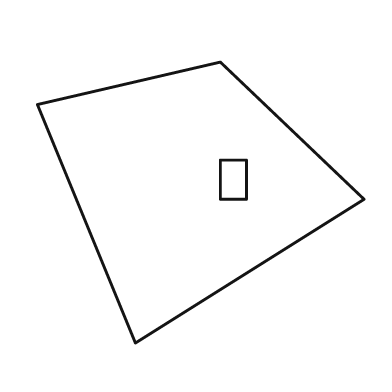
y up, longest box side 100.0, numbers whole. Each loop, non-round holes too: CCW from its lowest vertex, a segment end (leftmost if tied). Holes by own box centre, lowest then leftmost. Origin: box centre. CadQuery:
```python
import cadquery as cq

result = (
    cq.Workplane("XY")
    .moveTo(-20.0, -43.0)
    .lineTo(50.0, 1.0)
    .lineTo(6.0, 43.0)
    .lineTo(-50.0, 30.0)
    .close()
    .moveTo(6.0, 1.0)
    .lineTo(14.0, 1.0)
    .lineTo(14.0, 13.0)
    .lineTo(6.0, 13.0)
    .close()
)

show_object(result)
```